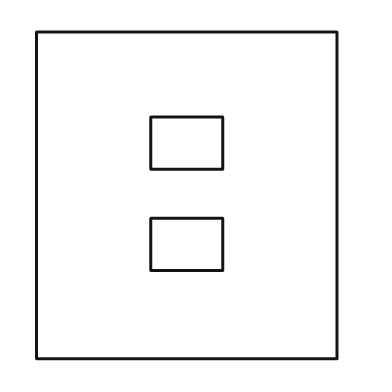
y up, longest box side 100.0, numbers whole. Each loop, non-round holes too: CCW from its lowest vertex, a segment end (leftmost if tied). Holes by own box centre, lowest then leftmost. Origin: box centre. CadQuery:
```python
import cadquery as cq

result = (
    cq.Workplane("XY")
    .moveTo(-46.0, -50.0)
    .lineTo(46.0, -50.0)
    .lineTo(46.0, 50.0)
    .lineTo(-46.0, 50.0)
    .close()
    .moveTo(-11.0, -23.0)
    .lineTo(11.0, -23.0)
    .lineTo(11.0, -7.0)
    .lineTo(-11.0, -7.0)
    .close()
    .moveTo(-11.0, 8.0)
    .lineTo(11.0, 8.0)
    .lineTo(11.0, 24.0)
    .lineTo(-11.0, 24.0)
    .close()
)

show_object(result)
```